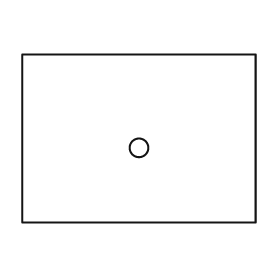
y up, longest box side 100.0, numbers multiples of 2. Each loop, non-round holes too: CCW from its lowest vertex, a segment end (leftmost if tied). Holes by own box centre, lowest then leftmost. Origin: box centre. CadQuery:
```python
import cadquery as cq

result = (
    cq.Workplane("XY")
    .moveTo(-50.0, -36.0)
    .lineTo(50.0, -36.0)
    .lineTo(50.0, 36.0)
    .lineTo(-50.0, 36.0)
    .close()
    .moveTo(0.0, -4.0)
    .circle(4.0)
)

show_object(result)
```